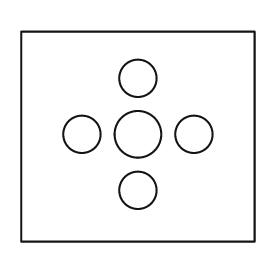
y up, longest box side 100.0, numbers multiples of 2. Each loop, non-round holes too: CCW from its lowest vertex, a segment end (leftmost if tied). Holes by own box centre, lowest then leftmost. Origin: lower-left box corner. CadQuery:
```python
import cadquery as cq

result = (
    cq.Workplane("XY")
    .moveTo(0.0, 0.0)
    .lineTo(100.0, 0.0)
    .lineTo(100.0, 90.0)
    .lineTo(0.0, 90.0)
    .close()
    .moveTo(50.0, 22.0)
    .circle(8.0)
    .moveTo(26.0, 46.0)
    .circle(8.0)
    .moveTo(50.0, 46.0)
    .circle(10.0)
    .moveTo(74.0, 46.0)
    .circle(8.0)
    .moveTo(50.0, 70.0)
    .circle(8.0)
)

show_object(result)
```